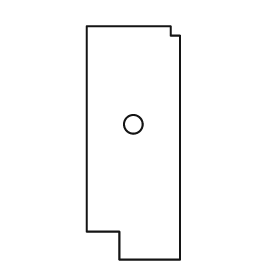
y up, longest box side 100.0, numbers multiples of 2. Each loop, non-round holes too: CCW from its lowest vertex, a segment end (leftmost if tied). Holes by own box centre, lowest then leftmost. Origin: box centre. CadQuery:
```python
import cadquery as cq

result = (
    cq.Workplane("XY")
    .moveTo(-6.0, -50.0)
    .lineTo(20.0, -50.0)
    .lineTo(20.0, 46.0)
    .lineTo(16.0, 46.0)
    .lineTo(16.0, 50.0)
    .lineTo(-20.0, 50.0)
    .lineTo(-20.0, -38.0)
    .lineTo(-6.0, -38.0)
    .close()
    .moveTo(0.0, 8.0)
    .circle(4.0)
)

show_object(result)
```